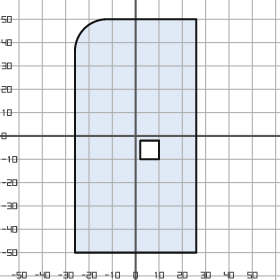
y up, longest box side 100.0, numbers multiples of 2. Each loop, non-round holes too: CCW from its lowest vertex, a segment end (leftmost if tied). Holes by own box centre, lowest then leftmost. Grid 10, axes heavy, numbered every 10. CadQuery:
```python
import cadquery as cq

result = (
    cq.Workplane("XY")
    .moveTo(-26.0, -50.0)
    .lineTo(26.0, -50.0)
    .lineTo(26.0, 50.0)
    .lineTo(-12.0, 50.0)
    .threePointArc((-22.0, 46.0), (-26.0, 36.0))
    .close()
    .moveTo(2.0, -10.0)
    .lineTo(10.0, -10.0)
    .lineTo(10.0, -2.0)
    .lineTo(2.0, -2.0)
    .close()
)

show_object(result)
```